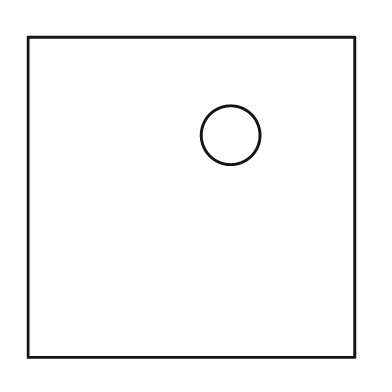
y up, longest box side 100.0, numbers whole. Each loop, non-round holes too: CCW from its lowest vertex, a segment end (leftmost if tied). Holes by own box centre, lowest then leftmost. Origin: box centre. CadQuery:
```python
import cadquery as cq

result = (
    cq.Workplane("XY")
    .moveTo(-50.0, -49.0)
    .lineTo(50.0, -49.0)
    .lineTo(50.0, 49.0)
    .lineTo(-50.0, 49.0)
    .close()
    .moveTo(12.0, 19.0)
    .circle(9.0)
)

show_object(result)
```